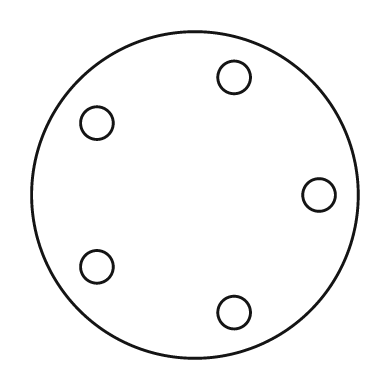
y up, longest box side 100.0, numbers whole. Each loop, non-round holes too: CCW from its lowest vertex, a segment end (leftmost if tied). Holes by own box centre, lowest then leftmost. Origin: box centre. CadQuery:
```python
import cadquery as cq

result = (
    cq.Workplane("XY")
    .moveTo(0.0, 0.0)
    .circle(50.0)
    .moveTo(12.0, -36.0)
    .circle(5.0)
    .moveTo(-30.0, -22.0)
    .circle(5.0)
    .moveTo(38.0, 0.0)
    .circle(5.0)
    .moveTo(-30.0, 22.0)
    .circle(5.0)
    .moveTo(12.0, 36.0)
    .circle(5.0)
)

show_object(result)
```